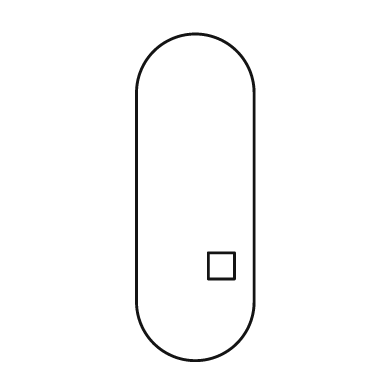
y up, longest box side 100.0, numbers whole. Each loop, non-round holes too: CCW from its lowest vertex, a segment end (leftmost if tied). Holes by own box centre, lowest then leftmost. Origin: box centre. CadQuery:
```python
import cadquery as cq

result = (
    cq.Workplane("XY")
    .moveTo(-18.0, -32.0)
    .threePointArc((0.0, -50.0), (18.0, -32.0))
    .lineTo(18.0, 32.0)
    .threePointArc((0.0, 50.0), (-18.0, 32.0))
    .close()
    .moveTo(4.0, -25.0)
    .lineTo(12.0, -25.0)
    .lineTo(12.0, -17.0)
    .lineTo(4.0, -17.0)
    .close()
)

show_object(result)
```